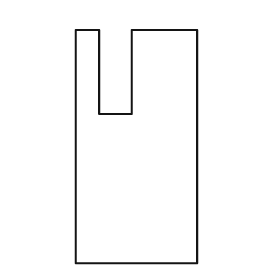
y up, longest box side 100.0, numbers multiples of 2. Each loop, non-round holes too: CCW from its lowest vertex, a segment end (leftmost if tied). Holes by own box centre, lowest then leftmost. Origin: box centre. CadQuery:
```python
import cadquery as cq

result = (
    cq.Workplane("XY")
    .moveTo(-26.0, -50.0)
    .lineTo(26.0, -50.0)
    .lineTo(26.0, 50.0)
    .lineTo(-2.0, 50.0)
    .lineTo(-2.0, 14.0)
    .lineTo(-16.0, 14.0)
    .lineTo(-16.0, 50.0)
    .lineTo(-26.0, 50.0)
    .close()
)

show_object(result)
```